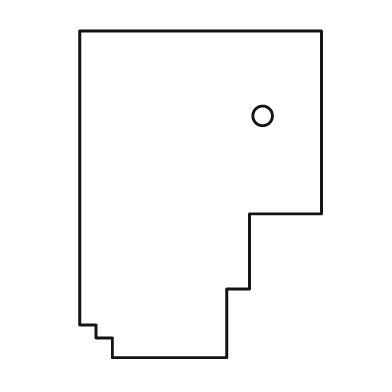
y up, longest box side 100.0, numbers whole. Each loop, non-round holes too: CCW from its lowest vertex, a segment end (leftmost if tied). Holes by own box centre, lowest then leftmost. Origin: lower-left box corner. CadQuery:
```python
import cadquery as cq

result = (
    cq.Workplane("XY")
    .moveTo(10.0, 0.0)
    .lineTo(45.0, 0.0)
    .lineTo(45.0, 21.0)
    .lineTo(52.0, 21.0)
    .lineTo(52.0, 44.0)
    .lineTo(74.0, 44.0)
    .lineTo(74.0, 100.0)
    .lineTo(0.0, 100.0)
    .lineTo(0.0, 10.0)
    .lineTo(5.0, 10.0)
    .lineTo(5.0, 6.0)
    .lineTo(10.0, 6.0)
    .close()
    .moveTo(56.0, 74.0)
    .circle(3.0)
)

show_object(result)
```